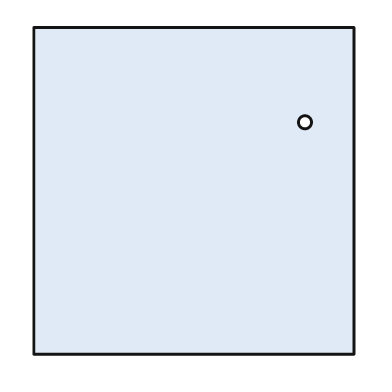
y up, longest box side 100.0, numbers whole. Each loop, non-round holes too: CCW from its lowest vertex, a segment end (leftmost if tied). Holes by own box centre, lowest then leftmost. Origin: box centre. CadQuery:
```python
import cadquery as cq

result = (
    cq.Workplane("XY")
    .moveTo(-49.0, -50.0)
    .lineTo(49.0, -50.0)
    .lineTo(49.0, 50.0)
    .lineTo(-49.0, 50.0)
    .close()
    .moveTo(34.0, 21.0)
    .circle(2.0)
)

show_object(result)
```